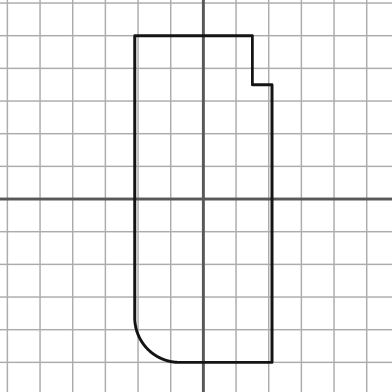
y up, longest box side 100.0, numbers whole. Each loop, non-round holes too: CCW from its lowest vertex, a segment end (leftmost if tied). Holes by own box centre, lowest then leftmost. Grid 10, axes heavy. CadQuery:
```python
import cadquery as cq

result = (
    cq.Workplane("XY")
    .moveTo(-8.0, -50.0)
    .lineTo(21.0, -50.0)
    .lineTo(21.0, 35.0)
    .lineTo(15.0, 35.0)
    .lineTo(15.0, 50.0)
    .lineTo(-21.0, 50.0)
    .lineTo(-21.0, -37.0)
    .threePointArc((-17.0, -46.0), (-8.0, -50.0))
    .close()
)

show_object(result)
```